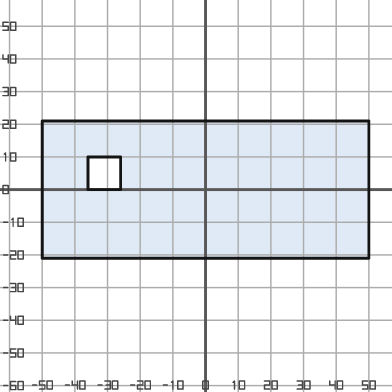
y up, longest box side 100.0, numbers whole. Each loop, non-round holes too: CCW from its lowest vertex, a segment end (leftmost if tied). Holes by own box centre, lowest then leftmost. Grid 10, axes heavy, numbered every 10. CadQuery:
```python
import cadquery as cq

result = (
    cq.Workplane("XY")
    .moveTo(-50.0, -21.0)
    .lineTo(50.0, -21.0)
    .lineTo(50.0, 21.0)
    .lineTo(-50.0, 21.0)
    .close()
    .moveTo(-36.0, 0.0)
    .lineTo(-26.0, 0.0)
    .lineTo(-26.0, 10.0)
    .lineTo(-36.0, 10.0)
    .close()
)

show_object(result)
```